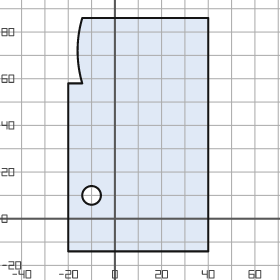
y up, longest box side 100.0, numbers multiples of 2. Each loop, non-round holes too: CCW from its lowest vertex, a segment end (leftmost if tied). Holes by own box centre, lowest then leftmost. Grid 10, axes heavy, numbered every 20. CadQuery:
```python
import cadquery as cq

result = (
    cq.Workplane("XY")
    .moveTo(-20.0, -14.0)
    .lineTo(40.0, -14.0)
    .lineTo(40.0, 86.0)
    .lineTo(-14.0, 86.0)
    .threePointArc((-16.0, 72.0), (-14.0, 58.0))
    .lineTo(-20.0, 58.0)
    .close()
    .moveTo(-10.0, 10.0)
    .circle(4.0)
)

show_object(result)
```